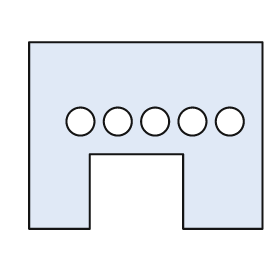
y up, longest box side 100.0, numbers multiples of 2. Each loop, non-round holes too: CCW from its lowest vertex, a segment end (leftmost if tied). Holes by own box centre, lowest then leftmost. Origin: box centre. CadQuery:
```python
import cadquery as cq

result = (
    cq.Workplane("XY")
    .moveTo(-50.0, -40.0)
    .lineTo(-24.0, -40.0)
    .lineTo(-24.0, -8.0)
    .lineTo(16.0, -8.0)
    .lineTo(16.0, -40.0)
    .lineTo(50.0, -40.0)
    .lineTo(50.0, 40.0)
    .lineTo(-50.0, 40.0)
    .close()
    .moveTo(-28.0, 6.0)
    .circle(6.0)
    .moveTo(-12.0, 6.0)
    .circle(6.0)
    .moveTo(4.0, 6.0)
    .circle(6.0)
    .moveTo(20.0, 6.0)
    .circle(6.0)
    .moveTo(36.0, 6.0)
    .circle(6.0)
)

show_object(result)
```